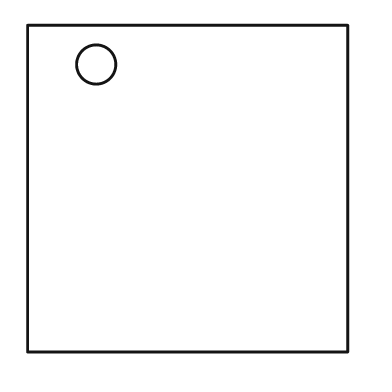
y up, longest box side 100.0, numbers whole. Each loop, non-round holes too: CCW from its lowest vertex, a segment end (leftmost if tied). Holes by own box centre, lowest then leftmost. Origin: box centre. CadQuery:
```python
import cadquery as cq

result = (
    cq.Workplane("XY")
    .moveTo(-49.0, -50.0)
    .lineTo(49.0, -50.0)
    .lineTo(49.0, 50.0)
    .lineTo(-49.0, 50.0)
    .close()
    .moveTo(-28.0, 38.0)
    .circle(6.0)
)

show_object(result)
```